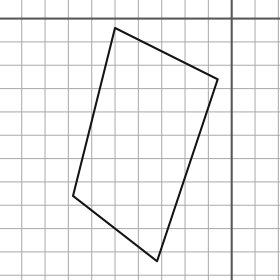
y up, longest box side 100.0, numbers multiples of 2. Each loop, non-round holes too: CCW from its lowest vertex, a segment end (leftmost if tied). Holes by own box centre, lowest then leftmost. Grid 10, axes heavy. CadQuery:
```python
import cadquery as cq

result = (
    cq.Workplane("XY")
    .moveTo(-32.0, -104.0)
    .lineTo(-6.0, -26.0)
    .lineTo(-50.0, -4.0)
    .lineTo(-68.0, -76.0)
    .close()
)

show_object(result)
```